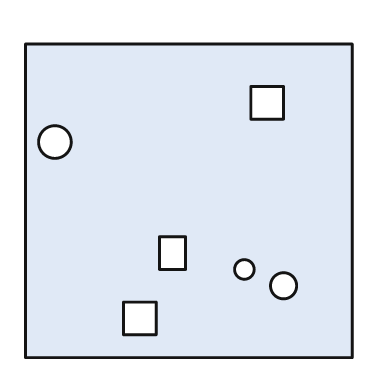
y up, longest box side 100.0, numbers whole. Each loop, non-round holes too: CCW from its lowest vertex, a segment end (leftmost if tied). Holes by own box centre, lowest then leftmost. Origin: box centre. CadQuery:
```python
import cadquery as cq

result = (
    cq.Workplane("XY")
    .moveTo(-50.0, -48.0)
    .lineTo(50.0, -48.0)
    .lineTo(50.0, 48.0)
    .lineTo(-50.0, 48.0)
    .close()
    .moveTo(-20.0, -41.0)
    .lineTo(-10.0, -41.0)
    .lineTo(-10.0, -31.0)
    .lineTo(-20.0, -31.0)
    .close()
    .moveTo(29.0, -26.0)
    .circle(4.0)
    .moveTo(17.0, -21.0)
    .circle(3.0)
    .moveTo(-9.0, -21.0)
    .lineTo(-1.0, -21.0)
    .lineTo(-1.0, -11.0)
    .lineTo(-9.0, -11.0)
    .close()
    .moveTo(-41.0, 18.0)
    .circle(5.0)
    .moveTo(19.0, 25.0)
    .lineTo(29.0, 25.0)
    .lineTo(29.0, 35.0)
    .lineTo(19.0, 35.0)
    .close()
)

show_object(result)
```